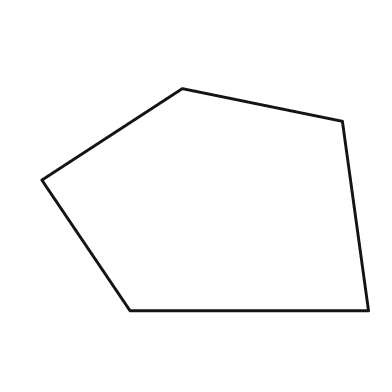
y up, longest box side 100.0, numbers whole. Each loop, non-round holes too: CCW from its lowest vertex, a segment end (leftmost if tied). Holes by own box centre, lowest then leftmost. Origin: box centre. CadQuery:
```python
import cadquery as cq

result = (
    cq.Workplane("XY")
    .moveTo(-23.0, -34.0)
    .lineTo(50.0, -34.0)
    .lineTo(42.0, 24.0)
    .lineTo(-7.0, 34.0)
    .lineTo(-50.0, 6.0)
    .close()
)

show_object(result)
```